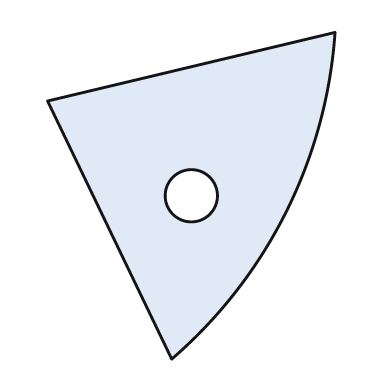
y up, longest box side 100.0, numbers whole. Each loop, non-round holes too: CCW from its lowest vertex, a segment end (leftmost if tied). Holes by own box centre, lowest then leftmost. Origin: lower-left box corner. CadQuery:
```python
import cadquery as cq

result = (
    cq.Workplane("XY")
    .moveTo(38.0, 0.0)
    .threePointArc((73.0, 45.0), (88.0, 100.0))
    .lineTo(0.0, 79.0)
    .close()
    .moveTo(44.0, 50.0)
    .circle(8.0)
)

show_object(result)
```